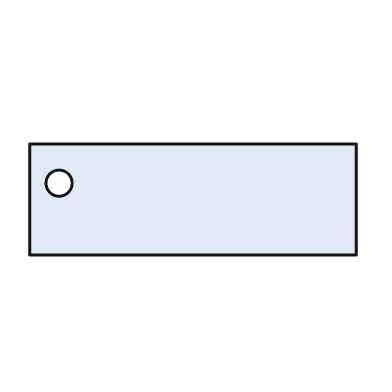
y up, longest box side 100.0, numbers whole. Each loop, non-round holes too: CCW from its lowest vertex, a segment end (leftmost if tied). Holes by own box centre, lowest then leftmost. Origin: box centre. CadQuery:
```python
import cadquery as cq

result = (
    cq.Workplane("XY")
    .moveTo(-50.0, -17.0)
    .lineTo(50.0, -17.0)
    .lineTo(50.0, 17.0)
    .lineTo(-50.0, 17.0)
    .close()
    .moveTo(-41.0, 5.0)
    .circle(4.0)
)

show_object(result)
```